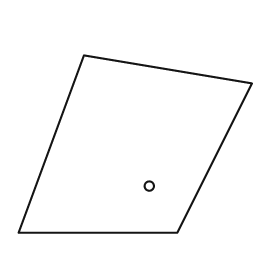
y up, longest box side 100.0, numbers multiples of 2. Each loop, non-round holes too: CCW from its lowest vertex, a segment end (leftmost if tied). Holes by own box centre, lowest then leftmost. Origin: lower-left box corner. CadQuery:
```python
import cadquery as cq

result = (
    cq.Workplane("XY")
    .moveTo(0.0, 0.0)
    .lineTo(68.0, 0.0)
    .lineTo(100.0, 64.0)
    .lineTo(28.0, 76.0)
    .close()
    .moveTo(56.0, 20.0)
    .circle(2.0)
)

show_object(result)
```